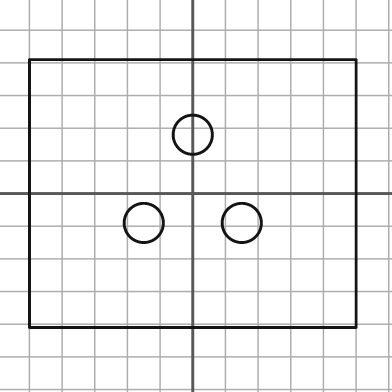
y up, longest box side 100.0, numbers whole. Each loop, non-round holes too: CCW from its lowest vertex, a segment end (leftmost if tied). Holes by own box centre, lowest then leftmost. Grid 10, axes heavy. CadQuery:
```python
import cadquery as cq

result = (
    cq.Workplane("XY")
    .moveTo(-50.0, -41.0)
    .lineTo(50.0, -41.0)
    .lineTo(50.0, 41.0)
    .lineTo(-50.0, 41.0)
    .close()
    .moveTo(-15.0, -9.0)
    .circle(6.0)
    .moveTo(15.0, -9.0)
    .circle(6.0)
    .moveTo(0.0, 18.0)
    .circle(6.0)
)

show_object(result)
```